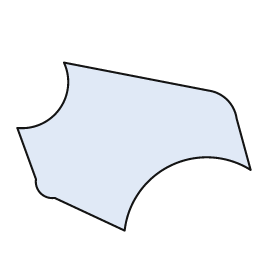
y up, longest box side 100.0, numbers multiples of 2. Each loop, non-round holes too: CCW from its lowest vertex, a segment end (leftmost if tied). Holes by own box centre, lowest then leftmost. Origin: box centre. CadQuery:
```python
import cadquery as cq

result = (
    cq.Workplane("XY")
    .moveTo(-4.0, -36.0)
    .threePointArc((16.0, -8.0), (50.0, -10.0))
    .lineTo(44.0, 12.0)
    .threePointArc((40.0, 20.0), (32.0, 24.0))
    .lineTo(-30.0, 36.0)
    .threePointArc((-32.0, 16.0), (-50.0, 8.0))
    .lineTo(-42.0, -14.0)
    .threePointArc((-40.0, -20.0), (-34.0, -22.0))
    .close()
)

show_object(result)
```